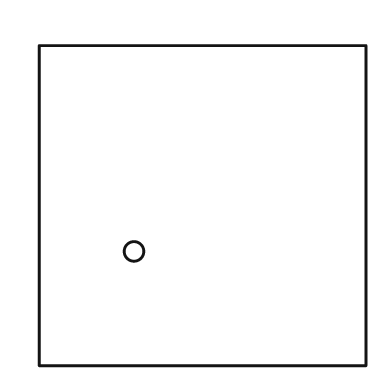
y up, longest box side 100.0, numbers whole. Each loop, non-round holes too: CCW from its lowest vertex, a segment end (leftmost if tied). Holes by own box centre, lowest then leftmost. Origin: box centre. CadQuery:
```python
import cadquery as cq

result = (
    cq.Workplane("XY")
    .moveTo(-50.0, -49.0)
    .lineTo(50.0, -49.0)
    .lineTo(50.0, 49.0)
    .lineTo(-50.0, 49.0)
    .close()
    .moveTo(-21.0, -14.0)
    .circle(3.0)
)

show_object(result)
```